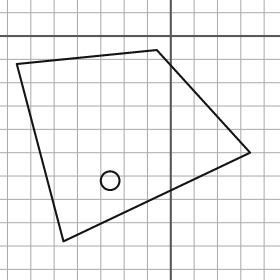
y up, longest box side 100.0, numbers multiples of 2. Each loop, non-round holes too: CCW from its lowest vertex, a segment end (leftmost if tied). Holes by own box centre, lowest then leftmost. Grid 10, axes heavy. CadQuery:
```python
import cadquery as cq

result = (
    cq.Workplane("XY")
    .moveTo(-46.0, -88.0)
    .lineTo(34.0, -50.0)
    .lineTo(-6.0, -6.0)
    .lineTo(-66.0, -12.0)
    .close()
    .moveTo(-26.0, -62.0)
    .circle(4.0)
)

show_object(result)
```